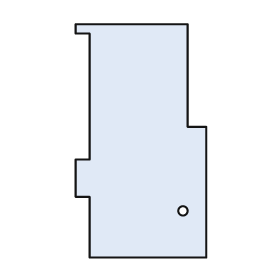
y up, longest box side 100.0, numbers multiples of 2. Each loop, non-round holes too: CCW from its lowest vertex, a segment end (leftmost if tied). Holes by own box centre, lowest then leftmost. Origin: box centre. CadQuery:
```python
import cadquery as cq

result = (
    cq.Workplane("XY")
    .moveTo(-22.0, -50.0)
    .lineTo(28.0, -50.0)
    .lineTo(28.0, 6.0)
    .lineTo(20.0, 6.0)
    .lineTo(20.0, 50.0)
    .lineTo(-28.0, 50.0)
    .lineTo(-28.0, 46.0)
    .lineTo(-22.0, 46.0)
    .lineTo(-22.0, -8.0)
    .lineTo(-28.0, -8.0)
    .lineTo(-28.0, -24.0)
    .lineTo(-22.0, -24.0)
    .close()
    .moveTo(18.0, -30.0)
    .circle(2.0)
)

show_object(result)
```